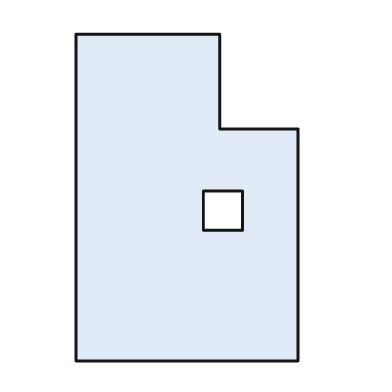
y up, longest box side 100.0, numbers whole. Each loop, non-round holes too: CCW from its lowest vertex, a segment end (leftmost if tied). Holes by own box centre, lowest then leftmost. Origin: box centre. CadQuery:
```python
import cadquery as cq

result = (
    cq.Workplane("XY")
    .moveTo(-34.0, -50.0)
    .lineTo(34.0, -50.0)
    .lineTo(34.0, 21.0)
    .lineTo(10.0, 21.0)
    .lineTo(10.0, 50.0)
    .lineTo(-34.0, 50.0)
    .close()
    .moveTo(5.0, -10.0)
    .lineTo(17.0, -10.0)
    .lineTo(17.0, 2.0)
    .lineTo(5.0, 2.0)
    .close()
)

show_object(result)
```